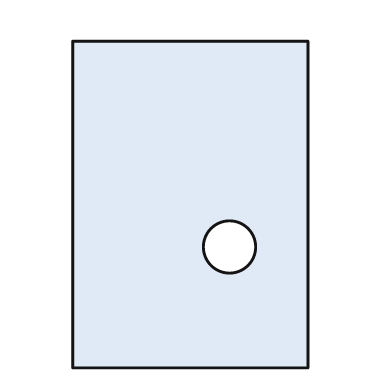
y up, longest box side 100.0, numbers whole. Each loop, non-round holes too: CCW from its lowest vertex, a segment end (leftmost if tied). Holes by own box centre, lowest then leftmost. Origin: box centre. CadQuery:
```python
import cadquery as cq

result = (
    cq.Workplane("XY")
    .moveTo(-36.0, -50.0)
    .lineTo(36.0, -50.0)
    .lineTo(36.0, 50.0)
    .lineTo(-36.0, 50.0)
    .close()
    .moveTo(12.0, -13.0)
    .circle(8.0)
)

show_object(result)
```